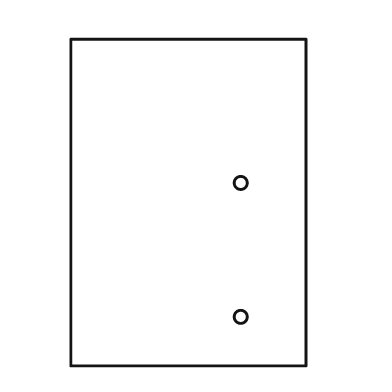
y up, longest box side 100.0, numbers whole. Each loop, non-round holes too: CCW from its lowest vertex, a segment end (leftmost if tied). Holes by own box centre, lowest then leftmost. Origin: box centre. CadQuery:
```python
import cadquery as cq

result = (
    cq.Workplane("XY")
    .moveTo(-36.0, -50.0)
    .lineTo(36.0, -50.0)
    .lineTo(36.0, 50.0)
    .lineTo(-36.0, 50.0)
    .close()
    .moveTo(16.0, -35.0)
    .circle(2.0)
    .moveTo(16.0, 6.0)
    .circle(2.0)
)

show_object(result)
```